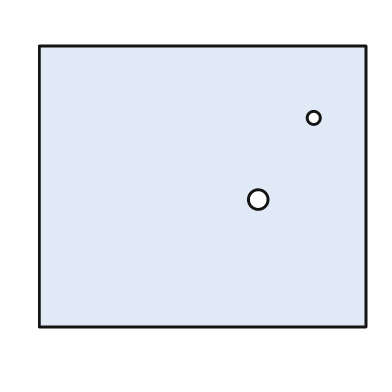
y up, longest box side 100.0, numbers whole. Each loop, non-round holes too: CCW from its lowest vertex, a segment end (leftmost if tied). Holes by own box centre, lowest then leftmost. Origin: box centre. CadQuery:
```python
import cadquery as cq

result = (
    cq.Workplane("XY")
    .moveTo(-50.0, -43.0)
    .lineTo(50.0, -43.0)
    .lineTo(50.0, 43.0)
    .lineTo(-50.0, 43.0)
    .close()
    .moveTo(17.0, -4.0)
    .circle(3.0)
    .moveTo(34.0, 21.0)
    .circle(2.0)
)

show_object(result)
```